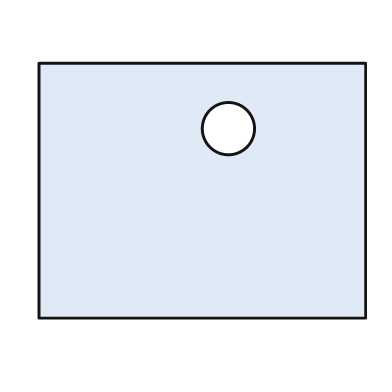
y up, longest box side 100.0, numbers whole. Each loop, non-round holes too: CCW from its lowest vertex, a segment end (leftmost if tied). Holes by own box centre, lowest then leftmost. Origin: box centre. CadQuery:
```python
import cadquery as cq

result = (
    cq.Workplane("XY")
    .moveTo(-50.0, -39.0)
    .lineTo(50.0, -39.0)
    .lineTo(50.0, 39.0)
    .lineTo(-50.0, 39.0)
    .close()
    .moveTo(8.0, 19.0)
    .circle(8.0)
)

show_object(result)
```